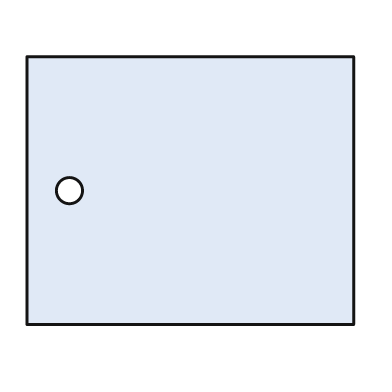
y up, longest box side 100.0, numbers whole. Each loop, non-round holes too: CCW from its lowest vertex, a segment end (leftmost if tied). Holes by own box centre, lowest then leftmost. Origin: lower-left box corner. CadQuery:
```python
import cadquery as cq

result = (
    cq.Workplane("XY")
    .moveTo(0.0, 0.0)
    .lineTo(100.0, 0.0)
    .lineTo(100.0, 82.0)
    .lineTo(0.0, 82.0)
    .close()
    .moveTo(13.0, 41.0)
    .circle(4.0)
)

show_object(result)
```